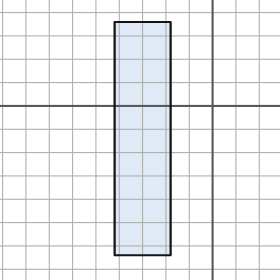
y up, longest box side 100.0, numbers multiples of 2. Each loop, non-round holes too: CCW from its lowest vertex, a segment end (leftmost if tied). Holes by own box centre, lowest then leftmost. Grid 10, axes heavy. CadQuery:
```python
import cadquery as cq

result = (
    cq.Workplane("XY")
    .moveTo(-42.0, -64.0)
    .lineTo(-18.0, -64.0)
    .lineTo(-18.0, 36.0)
    .lineTo(-42.0, 36.0)
    .close()
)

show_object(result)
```